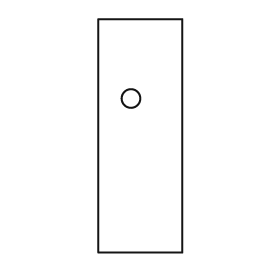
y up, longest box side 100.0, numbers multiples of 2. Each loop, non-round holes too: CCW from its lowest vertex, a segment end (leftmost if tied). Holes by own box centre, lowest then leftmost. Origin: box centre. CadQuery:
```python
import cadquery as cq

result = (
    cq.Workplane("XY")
    .moveTo(-18.0, -50.0)
    .lineTo(18.0, -50.0)
    .lineTo(18.0, 50.0)
    .lineTo(-18.0, 50.0)
    .close()
    .moveTo(-4.0, 16.0)
    .circle(4.0)
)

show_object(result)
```